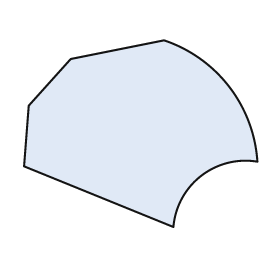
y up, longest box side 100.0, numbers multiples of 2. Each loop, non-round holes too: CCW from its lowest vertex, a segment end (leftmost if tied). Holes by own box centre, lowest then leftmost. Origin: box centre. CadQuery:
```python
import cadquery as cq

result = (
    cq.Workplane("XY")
    .moveTo(14.0, -40.0)
    .threePointArc((26.0, -18.0), (50.0, -12.0))
    .threePointArc((38.0, 20.0), (10.0, 40.0))
    .lineTo(-30.0, 32.0)
    .lineTo(-48.0, 12.0)
    .lineTo(-50.0, -14.0)
    .close()
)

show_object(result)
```